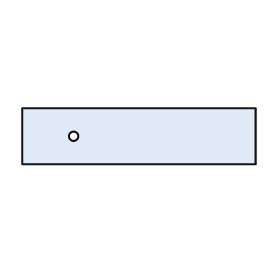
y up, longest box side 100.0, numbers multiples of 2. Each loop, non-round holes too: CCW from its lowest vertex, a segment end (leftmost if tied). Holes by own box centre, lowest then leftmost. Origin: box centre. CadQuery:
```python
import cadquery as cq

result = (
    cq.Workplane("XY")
    .moveTo(-50.0, -12.0)
    .lineTo(50.0, -12.0)
    .lineTo(50.0, 12.0)
    .lineTo(-50.0, 12.0)
    .close()
    .moveTo(-28.0, 0.0)
    .circle(2.0)
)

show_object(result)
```